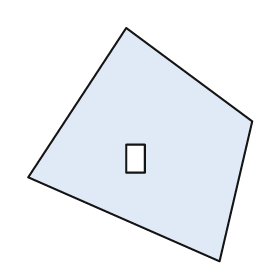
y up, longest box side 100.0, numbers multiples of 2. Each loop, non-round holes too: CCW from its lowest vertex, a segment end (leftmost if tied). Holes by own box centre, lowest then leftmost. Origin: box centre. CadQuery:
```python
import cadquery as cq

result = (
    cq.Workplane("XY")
    .moveTo(34.0, -50.0)
    .lineTo(48.0, 10.0)
    .lineTo(-6.0, 50.0)
    .lineTo(-48.0, -14.0)
    .close()
    .moveTo(-6.0, -12.0)
    .lineTo(2.0, -12.0)
    .lineTo(2.0, 0.0)
    .lineTo(-6.0, 0.0)
    .close()
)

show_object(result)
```